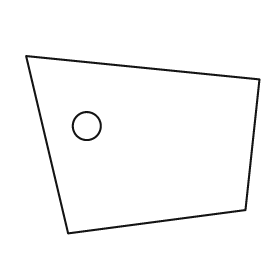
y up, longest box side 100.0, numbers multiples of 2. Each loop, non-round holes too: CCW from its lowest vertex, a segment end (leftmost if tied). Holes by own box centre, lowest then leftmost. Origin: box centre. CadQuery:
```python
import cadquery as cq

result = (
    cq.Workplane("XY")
    .moveTo(-32.0, -38.0)
    .lineTo(44.0, -28.0)
    .lineTo(50.0, 28.0)
    .lineTo(-50.0, 38.0)
    .close()
    .moveTo(-24.0, 8.0)
    .circle(6.0)
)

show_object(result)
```